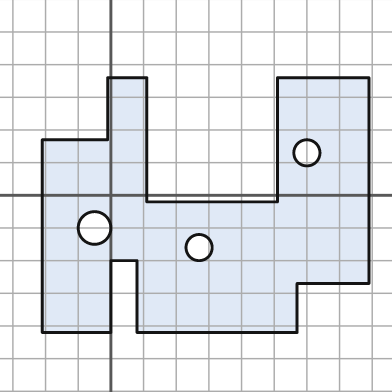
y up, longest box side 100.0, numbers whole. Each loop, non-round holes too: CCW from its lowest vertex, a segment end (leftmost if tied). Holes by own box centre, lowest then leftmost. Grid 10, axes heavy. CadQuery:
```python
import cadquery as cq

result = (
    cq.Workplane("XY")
    .moveTo(-21.0, -42.0)
    .lineTo(0.0, -42.0)
    .lineTo(0.0, -20.0)
    .lineTo(8.0, -20.0)
    .lineTo(8.0, -42.0)
    .lineTo(57.0, -42.0)
    .lineTo(57.0, -27.0)
    .lineTo(79.0, -27.0)
    .lineTo(79.0, 36.0)
    .lineTo(51.0, 36.0)
    .lineTo(51.0, -2.0)
    .lineTo(11.0, -2.0)
    .lineTo(11.0, 36.0)
    .lineTo(-1.0, 36.0)
    .lineTo(-1.0, 17.0)
    .lineTo(-21.0, 17.0)
    .close()
    .moveTo(27.0, -16.0)
    .circle(4.0)
    .moveTo(-5.0, -10.0)
    .circle(5.0)
    .moveTo(60.0, 13.0)
    .circle(4.0)
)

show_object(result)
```